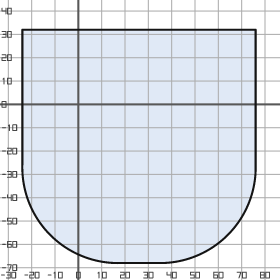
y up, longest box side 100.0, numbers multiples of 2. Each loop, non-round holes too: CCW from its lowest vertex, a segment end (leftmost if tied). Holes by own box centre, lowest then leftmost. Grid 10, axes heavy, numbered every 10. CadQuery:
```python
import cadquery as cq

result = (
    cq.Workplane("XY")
    .moveTo(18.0, -68.0)
    .lineTo(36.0, -68.0)
    .threePointArc((64.0, -56.0), (76.0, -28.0))
    .lineTo(76.0, 32.0)
    .lineTo(-24.0, 32.0)
    .lineTo(-24.0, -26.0)
    .threePointArc((-12.0, -56.0), (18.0, -68.0))
    .close()
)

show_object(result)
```